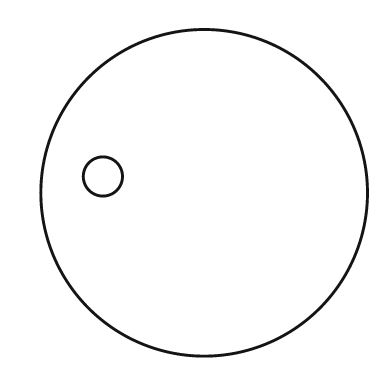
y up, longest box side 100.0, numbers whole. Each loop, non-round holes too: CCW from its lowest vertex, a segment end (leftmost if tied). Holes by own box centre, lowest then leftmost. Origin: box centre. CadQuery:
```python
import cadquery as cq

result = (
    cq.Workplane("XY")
    .moveTo(0.0, 0.0)
    .circle(50.0)
    .moveTo(-31.0, 5.0)
    .circle(6.0)
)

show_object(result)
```